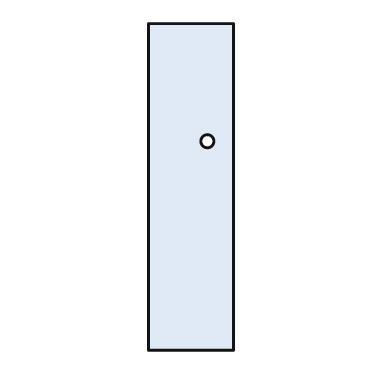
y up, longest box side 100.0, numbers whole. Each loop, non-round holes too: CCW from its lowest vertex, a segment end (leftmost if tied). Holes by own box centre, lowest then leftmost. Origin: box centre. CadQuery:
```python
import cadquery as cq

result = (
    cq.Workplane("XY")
    .moveTo(-13.0, -50.0)
    .lineTo(13.0, -50.0)
    .lineTo(13.0, 50.0)
    .lineTo(-13.0, 50.0)
    .close()
    .moveTo(5.0, 14.0)
    .circle(2.0)
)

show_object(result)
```